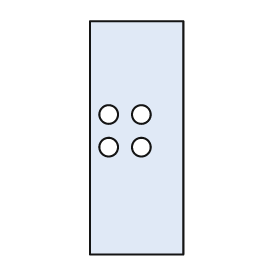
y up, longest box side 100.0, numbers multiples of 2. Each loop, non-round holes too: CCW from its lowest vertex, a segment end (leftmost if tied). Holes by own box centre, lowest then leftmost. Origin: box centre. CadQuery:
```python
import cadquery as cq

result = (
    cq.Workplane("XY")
    .moveTo(-20.0, -50.0)
    .lineTo(20.0, -50.0)
    .lineTo(20.0, 50.0)
    .lineTo(-20.0, 50.0)
    .close()
    .moveTo(-12.0, -4.0)
    .circle(4.0)
    .moveTo(2.0, -4.0)
    .circle(4.0)
    .moveTo(-12.0, 10.0)
    .circle(4.0)
    .moveTo(2.0, 10.0)
    .circle(4.0)
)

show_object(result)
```